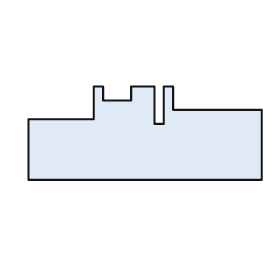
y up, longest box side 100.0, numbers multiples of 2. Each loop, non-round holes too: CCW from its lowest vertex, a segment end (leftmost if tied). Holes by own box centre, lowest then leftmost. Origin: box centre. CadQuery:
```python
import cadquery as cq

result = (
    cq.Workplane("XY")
    .moveTo(-50.0, -20.0)
    .lineTo(50.0, -20.0)
    .lineTo(50.0, 10.0)
    .lineTo(12.0, 10.0)
    .lineTo(12.0, 20.0)
    .lineTo(8.0, 20.0)
    .lineTo(8.0, 4.0)
    .lineTo(4.0, 4.0)
    .lineTo(4.0, 20.0)
    .lineTo(-6.0, 20.0)
    .lineTo(-6.0, 14.0)
    .lineTo(-18.0, 14.0)
    .lineTo(-18.0, 20.0)
    .lineTo(-22.0, 20.0)
    .lineTo(-22.0, 6.0)
    .lineTo(-50.0, 6.0)
    .close()
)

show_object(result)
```